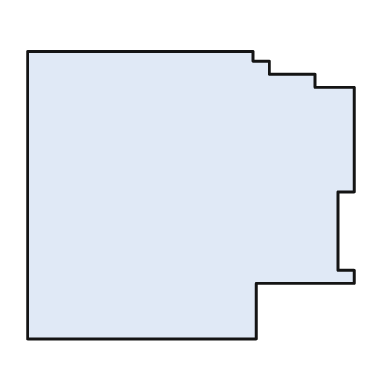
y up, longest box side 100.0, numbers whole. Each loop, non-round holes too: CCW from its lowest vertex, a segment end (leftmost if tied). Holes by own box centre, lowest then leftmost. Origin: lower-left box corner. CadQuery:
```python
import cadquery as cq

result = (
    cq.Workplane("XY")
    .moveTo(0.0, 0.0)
    .lineTo(70.0, 0.0)
    .lineTo(70.0, 17.0)
    .lineTo(100.0, 17.0)
    .lineTo(100.0, 21.0)
    .lineTo(95.0, 21.0)
    .lineTo(95.0, 45.0)
    .lineTo(100.0, 45.0)
    .lineTo(100.0, 77.0)
    .lineTo(88.0, 77.0)
    .lineTo(88.0, 81.0)
    .lineTo(74.0, 81.0)
    .lineTo(74.0, 85.0)
    .lineTo(69.0, 85.0)
    .lineTo(69.0, 88.0)
    .lineTo(0.0, 88.0)
    .close()
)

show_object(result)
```